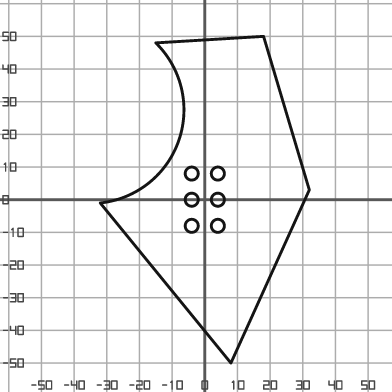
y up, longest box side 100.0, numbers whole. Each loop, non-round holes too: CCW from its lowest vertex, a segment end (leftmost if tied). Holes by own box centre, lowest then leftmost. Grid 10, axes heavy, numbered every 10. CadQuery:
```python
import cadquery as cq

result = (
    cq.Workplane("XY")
    .moveTo(8.0, -50.0)
    .lineTo(32.0, 3.0)
    .lineTo(18.0, 50.0)
    .lineTo(-15.0, 48.0)
    .threePointArc((-8.0, 18.0), (-32.0, -1.0))
    .close()
    .moveTo(-4.0, -8.0)
    .circle(2.0)
    .moveTo(4.0, -8.0)
    .circle(2.0)
    .moveTo(-4.0, 0.0)
    .circle(2.0)
    .moveTo(4.0, 0.0)
    .circle(2.0)
    .moveTo(-4.0, 8.0)
    .circle(2.0)
    .moveTo(4.0, 8.0)
    .circle(2.0)
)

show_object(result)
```